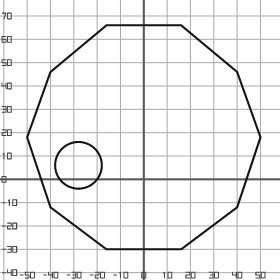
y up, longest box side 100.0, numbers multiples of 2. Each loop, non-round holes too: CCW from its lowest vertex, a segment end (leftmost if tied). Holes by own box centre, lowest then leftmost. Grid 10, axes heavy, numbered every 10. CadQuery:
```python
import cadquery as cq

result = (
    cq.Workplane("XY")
    .moveTo(-16.0, -30.0)
    .lineTo(16.0, -30.0)
    .lineTo(40.0, -12.0)
    .lineTo(50.0, 18.0)
    .lineTo(40.0, 46.0)
    .lineTo(16.0, 66.0)
    .lineTo(-16.0, 66.0)
    .lineTo(-40.0, 46.0)
    .lineTo(-50.0, 18.0)
    .lineTo(-40.0, -12.0)
    .close()
    .moveTo(-28.0, 6.0)
    .circle(10.0)
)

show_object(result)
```